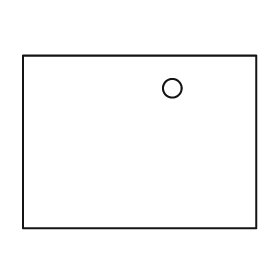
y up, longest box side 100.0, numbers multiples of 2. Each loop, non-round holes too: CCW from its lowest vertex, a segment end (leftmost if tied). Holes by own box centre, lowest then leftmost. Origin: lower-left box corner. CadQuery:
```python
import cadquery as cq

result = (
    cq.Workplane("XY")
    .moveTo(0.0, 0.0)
    .lineTo(100.0, 0.0)
    .lineTo(100.0, 74.0)
    .lineTo(0.0, 74.0)
    .close()
    .moveTo(64.0, 60.0)
    .circle(4.0)
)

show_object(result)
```